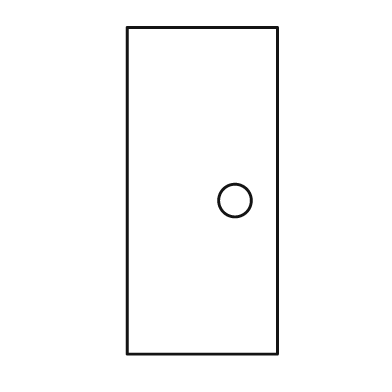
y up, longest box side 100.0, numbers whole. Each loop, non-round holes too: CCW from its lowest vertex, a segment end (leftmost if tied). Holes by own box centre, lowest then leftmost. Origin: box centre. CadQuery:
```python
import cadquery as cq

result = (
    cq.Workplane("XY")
    .moveTo(-23.0, -50.0)
    .lineTo(23.0, -50.0)
    .lineTo(23.0, 50.0)
    .lineTo(-23.0, 50.0)
    .close()
    .moveTo(10.0, -3.0)
    .circle(5.0)
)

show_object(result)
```